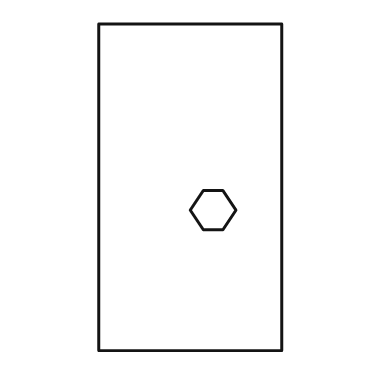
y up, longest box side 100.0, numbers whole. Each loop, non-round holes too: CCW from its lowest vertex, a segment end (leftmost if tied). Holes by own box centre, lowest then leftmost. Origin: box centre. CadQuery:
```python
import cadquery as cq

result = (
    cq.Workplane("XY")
    .moveTo(-28.0, -50.0)
    .lineTo(28.0, -50.0)
    .lineTo(28.0, 50.0)
    .lineTo(-28.0, 50.0)
    .close()
    .moveTo(4.0, -13.0)
    .lineTo(10.0, -13.0)
    .lineTo(14.0, -7.0)
    .lineTo(10.0, -1.0)
    .lineTo(4.0, -1.0)
    .lineTo(0.0, -7.0)
    .close()
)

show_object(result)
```